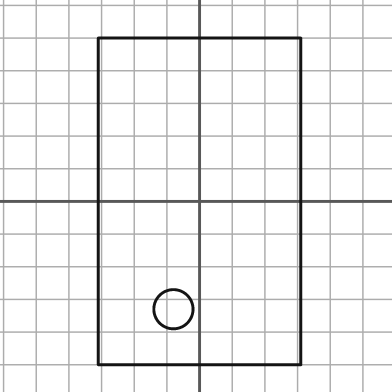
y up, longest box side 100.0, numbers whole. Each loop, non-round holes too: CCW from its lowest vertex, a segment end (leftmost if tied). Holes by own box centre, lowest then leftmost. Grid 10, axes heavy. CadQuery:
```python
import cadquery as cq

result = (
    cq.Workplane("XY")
    .moveTo(-31.0, -50.0)
    .lineTo(31.0, -50.0)
    .lineTo(31.0, 50.0)
    .lineTo(-31.0, 50.0)
    .close()
    .moveTo(-8.0, -33.0)
    .circle(6.0)
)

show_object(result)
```